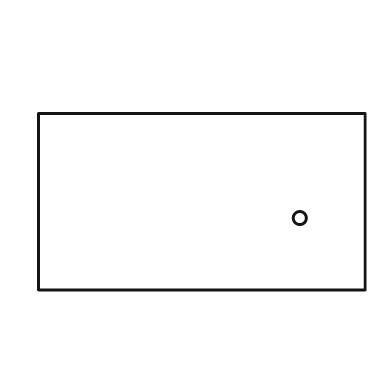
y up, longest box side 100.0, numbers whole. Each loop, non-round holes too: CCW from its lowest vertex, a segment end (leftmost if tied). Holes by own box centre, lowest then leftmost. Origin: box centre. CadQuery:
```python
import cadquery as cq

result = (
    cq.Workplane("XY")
    .moveTo(-50.0, -27.0)
    .lineTo(50.0, -27.0)
    .lineTo(50.0, 27.0)
    .lineTo(-50.0, 27.0)
    .close()
    .moveTo(30.0, -5.0)
    .circle(2.0)
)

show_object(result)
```